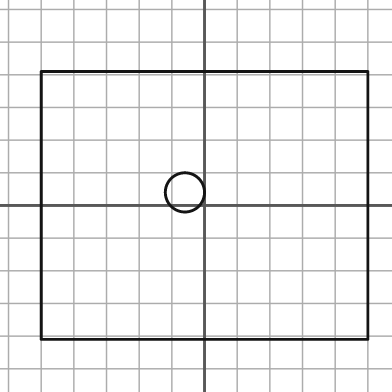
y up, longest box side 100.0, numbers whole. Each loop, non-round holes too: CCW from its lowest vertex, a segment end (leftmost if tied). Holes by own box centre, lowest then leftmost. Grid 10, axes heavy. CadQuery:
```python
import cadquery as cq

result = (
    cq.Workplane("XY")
    .moveTo(-50.0, -41.0)
    .lineTo(50.0, -41.0)
    .lineTo(50.0, 41.0)
    .lineTo(-50.0, 41.0)
    .close()
    .moveTo(-6.0, 4.0)
    .circle(6.0)
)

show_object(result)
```